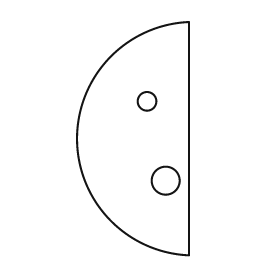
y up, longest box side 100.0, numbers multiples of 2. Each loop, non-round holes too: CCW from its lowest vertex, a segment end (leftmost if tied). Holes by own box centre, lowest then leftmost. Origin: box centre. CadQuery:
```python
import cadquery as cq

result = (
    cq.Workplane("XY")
    .moveTo(24.0, -50.0)
    .lineTo(24.0, 50.0)
    .threePointArc((-24.0, 0.0), (24.0, -50.0))
    .close()
    .moveTo(14.0, -18.0)
    .circle(6.0)
    .moveTo(6.0, 16.0)
    .circle(4.0)
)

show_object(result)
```